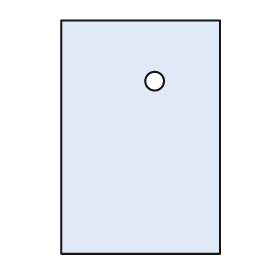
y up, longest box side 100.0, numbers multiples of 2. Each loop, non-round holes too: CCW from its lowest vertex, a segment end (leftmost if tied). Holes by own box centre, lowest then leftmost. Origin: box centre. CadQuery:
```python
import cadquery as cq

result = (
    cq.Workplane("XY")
    .moveTo(-34.0, -50.0)
    .lineTo(34.0, -50.0)
    .lineTo(34.0, 50.0)
    .lineTo(-34.0, 50.0)
    .close()
    .moveTo(6.0, 24.0)
    .circle(4.0)
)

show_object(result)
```